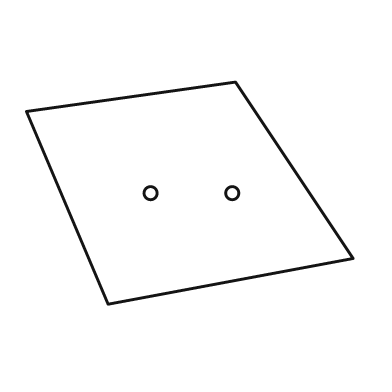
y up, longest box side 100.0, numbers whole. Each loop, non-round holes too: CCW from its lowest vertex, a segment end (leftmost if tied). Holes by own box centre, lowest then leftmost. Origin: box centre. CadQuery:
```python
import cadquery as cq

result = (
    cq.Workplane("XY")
    .moveTo(-25.0, -34.0)
    .lineTo(50.0, -20.0)
    .lineTo(14.0, 34.0)
    .lineTo(-50.0, 25.0)
    .close()
    .moveTo(-12.0, 0.0)
    .circle(2.0)
    .moveTo(13.0, 0.0)
    .circle(2.0)
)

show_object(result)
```